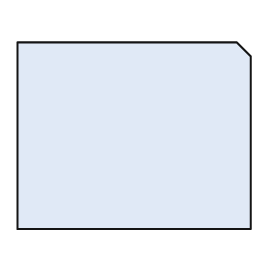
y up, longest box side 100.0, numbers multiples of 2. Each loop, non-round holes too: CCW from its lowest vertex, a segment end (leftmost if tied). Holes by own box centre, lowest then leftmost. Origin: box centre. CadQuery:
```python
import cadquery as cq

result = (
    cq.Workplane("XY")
    .moveTo(-50.0, -40.0)
    .lineTo(50.0, -40.0)
    .lineTo(50.0, 34.0)
    .lineTo(44.0, 40.0)
    .lineTo(-50.0, 40.0)
    .close()
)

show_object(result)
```